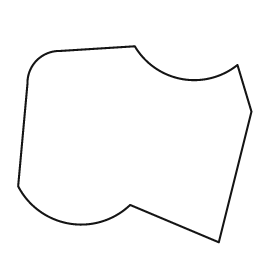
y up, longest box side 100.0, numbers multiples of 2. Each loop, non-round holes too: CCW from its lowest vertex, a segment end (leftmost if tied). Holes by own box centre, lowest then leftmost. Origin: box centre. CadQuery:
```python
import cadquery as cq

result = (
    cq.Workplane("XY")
    .moveTo(36.0, -42.0)
    .lineTo(50.0, 14.0)
    .lineTo(44.0, 34.0)
    .threePointArc((20.0, 28.0), (0.0, 42.0))
    .lineTo(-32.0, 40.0)
    .threePointArc((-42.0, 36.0), (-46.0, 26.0))
    .lineTo(-50.0, -18.0)
    .threePointArc((-28.0, -34.0), (-2.0, -26.0))
    .close()
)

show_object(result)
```